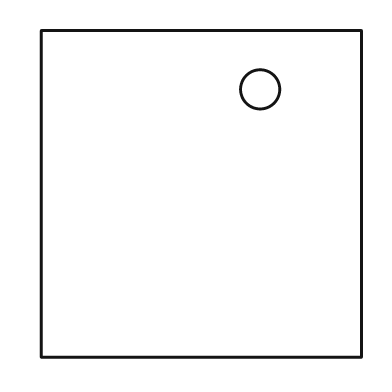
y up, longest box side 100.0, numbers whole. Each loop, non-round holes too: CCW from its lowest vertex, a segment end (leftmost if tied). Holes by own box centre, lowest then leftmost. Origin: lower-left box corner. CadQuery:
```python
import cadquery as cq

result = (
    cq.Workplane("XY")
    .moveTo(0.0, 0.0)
    .lineTo(98.0, 0.0)
    .lineTo(98.0, 100.0)
    .lineTo(0.0, 100.0)
    .close()
    .moveTo(67.0, 82.0)
    .circle(6.0)
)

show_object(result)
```